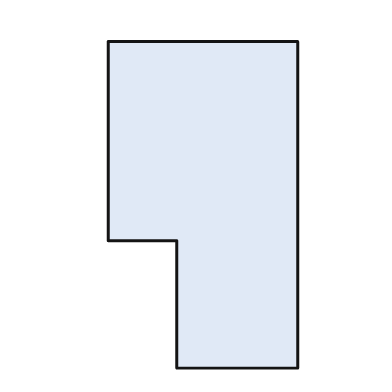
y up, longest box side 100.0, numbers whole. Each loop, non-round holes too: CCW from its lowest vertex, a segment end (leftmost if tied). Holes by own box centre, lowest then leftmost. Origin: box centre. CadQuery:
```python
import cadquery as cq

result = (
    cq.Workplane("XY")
    .moveTo(-8.0, -50.0)
    .lineTo(29.0, -50.0)
    .lineTo(29.0, 50.0)
    .lineTo(-29.0, 50.0)
    .lineTo(-29.0, -11.0)
    .lineTo(-8.0, -11.0)
    .close()
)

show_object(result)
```